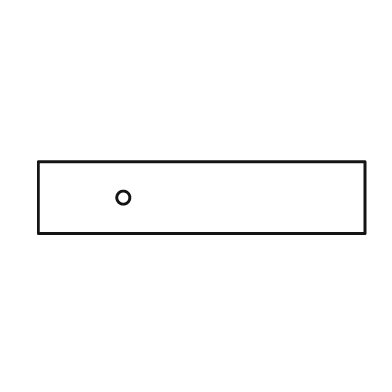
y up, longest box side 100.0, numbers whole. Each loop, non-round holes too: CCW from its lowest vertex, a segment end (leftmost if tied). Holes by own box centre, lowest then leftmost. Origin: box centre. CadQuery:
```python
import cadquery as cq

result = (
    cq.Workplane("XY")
    .moveTo(-50.0, -11.0)
    .lineTo(50.0, -11.0)
    .lineTo(50.0, 11.0)
    .lineTo(-50.0, 11.0)
    .close()
    .moveTo(-24.0, 0.0)
    .circle(2.0)
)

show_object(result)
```